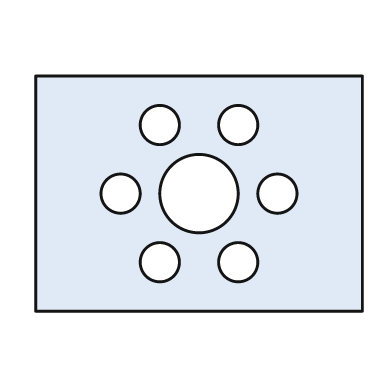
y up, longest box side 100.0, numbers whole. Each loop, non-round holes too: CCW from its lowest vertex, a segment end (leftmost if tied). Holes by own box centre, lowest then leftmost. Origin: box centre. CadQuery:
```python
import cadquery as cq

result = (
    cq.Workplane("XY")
    .moveTo(-50.0, -36.0)
    .lineTo(50.0, -36.0)
    .lineTo(50.0, 36.0)
    .lineTo(-50.0, 36.0)
    .close()
    .moveTo(-12.0, -21.0)
    .circle(6.0)
    .moveTo(12.0, -21.0)
    .circle(6.0)
    .moveTo(-24.0, 0.0)
    .circle(6.0)
    .moveTo(0.0, 0.0)
    .circle(12.0)
    .moveTo(24.0, 0.0)
    .circle(6.0)
    .moveTo(-12.0, 21.0)
    .circle(6.0)
    .moveTo(12.0, 21.0)
    .circle(6.0)
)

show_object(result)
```